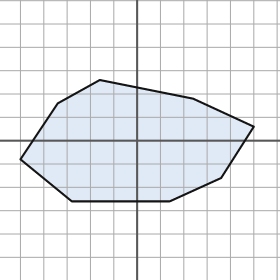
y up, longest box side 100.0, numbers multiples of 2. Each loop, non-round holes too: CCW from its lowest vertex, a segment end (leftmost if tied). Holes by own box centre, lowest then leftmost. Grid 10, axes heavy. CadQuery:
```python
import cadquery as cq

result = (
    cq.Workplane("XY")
    .moveTo(-28.0, -26.0)
    .lineTo(14.0, -26.0)
    .lineTo(36.0, -16.0)
    .lineTo(50.0, 6.0)
    .lineTo(24.0, 18.0)
    .lineTo(-16.0, 26.0)
    .lineTo(-34.0, 16.0)
    .lineTo(-50.0, -8.0)
    .close()
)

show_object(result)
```